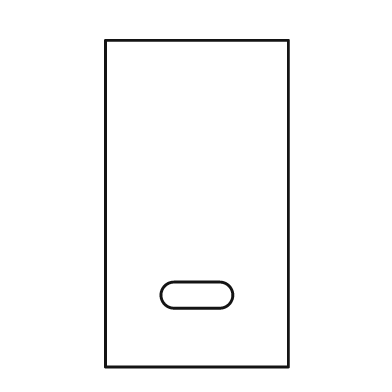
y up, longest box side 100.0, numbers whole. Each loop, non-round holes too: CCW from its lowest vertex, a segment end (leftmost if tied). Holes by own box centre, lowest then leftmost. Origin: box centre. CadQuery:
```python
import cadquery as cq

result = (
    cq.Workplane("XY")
    .moveTo(-28.0, -50.0)
    .lineTo(28.0, -50.0)
    .lineTo(28.0, 50.0)
    .lineTo(-28.0, 50.0)
    .close()
    .moveTo(-7.0, -32.0)
    .lineTo(7.0, -32.0)
    .threePointArc((11.0, -28.0), (7.0, -24.0))
    .lineTo(-7.0, -24.0)
    .threePointArc((-11.0, -28.0), (-7.0, -32.0))
    .close()
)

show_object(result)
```